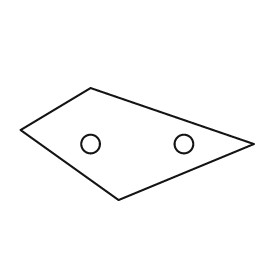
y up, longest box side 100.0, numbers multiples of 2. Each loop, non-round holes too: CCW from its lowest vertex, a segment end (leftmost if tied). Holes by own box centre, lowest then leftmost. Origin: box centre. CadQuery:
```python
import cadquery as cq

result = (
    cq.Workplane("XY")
    .moveTo(-8.0, -24.0)
    .lineTo(50.0, 0.0)
    .lineTo(-20.0, 24.0)
    .lineTo(-50.0, 6.0)
    .close()
    .moveTo(-20.0, 0.0)
    .circle(4.0)
    .moveTo(20.0, 0.0)
    .circle(4.0)
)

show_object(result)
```